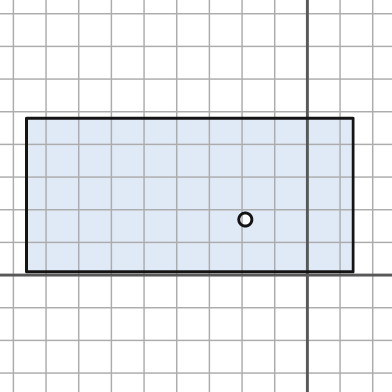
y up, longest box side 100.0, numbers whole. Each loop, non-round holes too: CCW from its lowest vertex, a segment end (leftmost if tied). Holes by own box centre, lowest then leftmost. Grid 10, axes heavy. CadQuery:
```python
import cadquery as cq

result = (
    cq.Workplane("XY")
    .moveTo(-86.0, 1.0)
    .lineTo(14.0, 1.0)
    .lineTo(14.0, 48.0)
    .lineTo(-86.0, 48.0)
    .close()
    .moveTo(-19.0, 17.0)
    .circle(2.0)
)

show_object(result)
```